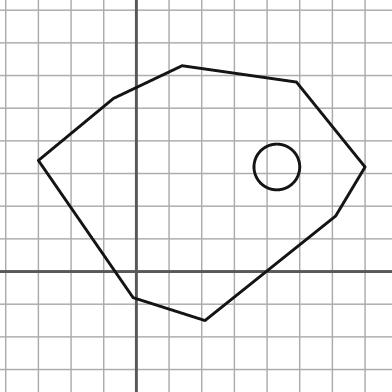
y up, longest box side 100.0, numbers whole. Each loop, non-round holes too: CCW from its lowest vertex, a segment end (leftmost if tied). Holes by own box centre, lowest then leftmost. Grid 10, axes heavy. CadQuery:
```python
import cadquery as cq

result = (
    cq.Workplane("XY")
    .moveTo(21.0, -15.0)
    .lineTo(61.0, 17.0)
    .lineTo(70.0, 32.0)
    .lineTo(49.0, 58.0)
    .lineTo(14.0, 63.0)
    .lineTo(-7.0, 53.0)
    .lineTo(-30.0, 34.0)
    .lineTo(-1.0, -8.0)
    .close()
    .moveTo(43.0, 32.0)
    .circle(7.0)
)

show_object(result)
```